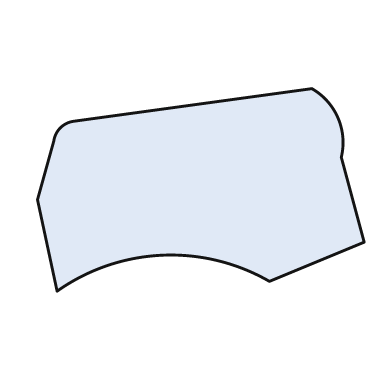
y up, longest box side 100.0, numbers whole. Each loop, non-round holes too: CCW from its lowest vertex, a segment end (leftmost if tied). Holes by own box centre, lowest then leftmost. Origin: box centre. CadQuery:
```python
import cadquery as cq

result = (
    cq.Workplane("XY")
    .moveTo(-44.0, -31.0)
    .threePointArc((-12.0, -20.0), (21.0, -28.0))
    .lineTo(50.0, -16.0)
    .lineTo(43.0, 10.0)
    .threePointArc((42.0, 22.0), (34.0, 31.0))
    .lineTo(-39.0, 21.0)
    .threePointArc((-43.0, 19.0), (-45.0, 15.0))
    .lineTo(-50.0, -3.0)
    .close()
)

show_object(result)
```